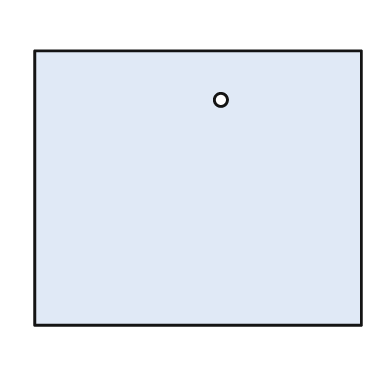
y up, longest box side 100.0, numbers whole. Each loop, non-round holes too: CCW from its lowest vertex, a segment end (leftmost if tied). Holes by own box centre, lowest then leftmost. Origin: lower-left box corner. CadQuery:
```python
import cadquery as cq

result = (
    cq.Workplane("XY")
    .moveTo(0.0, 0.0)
    .lineTo(100.0, 0.0)
    .lineTo(100.0, 84.0)
    .lineTo(0.0, 84.0)
    .close()
    .moveTo(57.0, 69.0)
    .circle(2.0)
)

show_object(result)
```